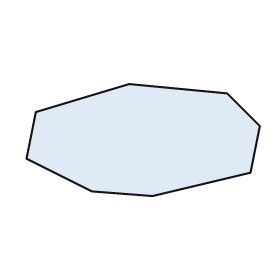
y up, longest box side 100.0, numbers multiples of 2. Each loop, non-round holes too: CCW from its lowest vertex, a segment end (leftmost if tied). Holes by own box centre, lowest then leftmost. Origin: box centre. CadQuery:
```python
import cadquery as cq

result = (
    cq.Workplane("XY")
    .moveTo(4.0, -24.0)
    .lineTo(46.0, -14.0)
    .lineTo(50.0, 6.0)
    .lineTo(36.0, 20.0)
    .lineTo(-6.0, 24.0)
    .lineTo(-46.0, 12.0)
    .lineTo(-50.0, -8.0)
    .lineTo(-22.0, -22.0)
    .close()
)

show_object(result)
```